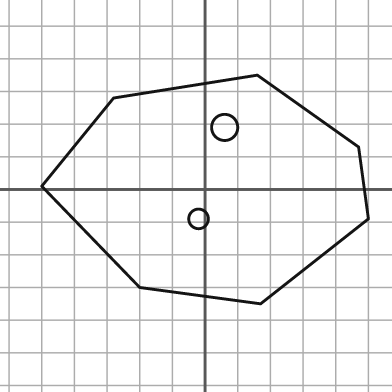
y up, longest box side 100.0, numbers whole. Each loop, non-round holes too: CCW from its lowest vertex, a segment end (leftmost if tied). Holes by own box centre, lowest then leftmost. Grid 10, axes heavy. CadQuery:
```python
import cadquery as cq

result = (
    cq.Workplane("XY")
    .moveTo(17.0, -35.0)
    .lineTo(50.0, -9.0)
    .lineTo(47.0, 13.0)
    .lineTo(16.0, 35.0)
    .lineTo(-28.0, 28.0)
    .lineTo(-50.0, 1.0)
    .lineTo(-20.0, -30.0)
    .close()
    .moveTo(-2.0, -9.0)
    .circle(3.0)
    .moveTo(6.0, 19.0)
    .circle(4.0)
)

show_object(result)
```